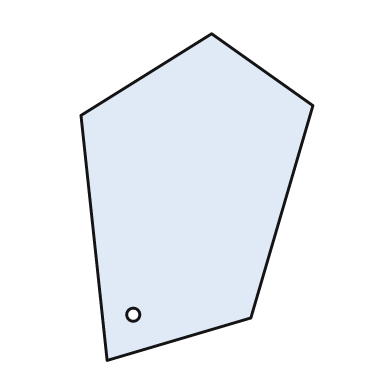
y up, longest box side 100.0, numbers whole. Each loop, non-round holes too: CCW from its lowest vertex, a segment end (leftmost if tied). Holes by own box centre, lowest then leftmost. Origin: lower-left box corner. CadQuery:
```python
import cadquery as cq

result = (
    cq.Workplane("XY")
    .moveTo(8.0, 0.0)
    .lineTo(52.0, 13.0)
    .lineTo(71.0, 78.0)
    .lineTo(40.0, 100.0)
    .lineTo(0.0, 75.0)
    .close()
    .moveTo(16.0, 14.0)
    .circle(2.0)
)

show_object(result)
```